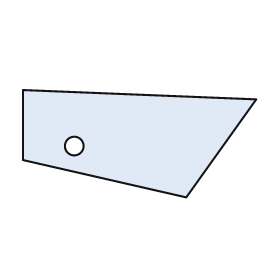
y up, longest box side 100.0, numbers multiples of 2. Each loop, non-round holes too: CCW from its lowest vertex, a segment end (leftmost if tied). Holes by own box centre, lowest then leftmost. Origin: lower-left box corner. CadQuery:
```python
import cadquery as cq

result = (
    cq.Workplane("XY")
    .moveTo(70.0, 0.0)
    .lineTo(100.0, 42.0)
    .lineTo(0.0, 46.0)
    .lineTo(0.0, 16.0)
    .close()
    .moveTo(22.0, 22.0)
    .circle(4.0)
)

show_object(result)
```